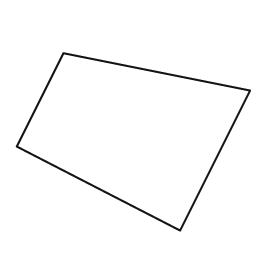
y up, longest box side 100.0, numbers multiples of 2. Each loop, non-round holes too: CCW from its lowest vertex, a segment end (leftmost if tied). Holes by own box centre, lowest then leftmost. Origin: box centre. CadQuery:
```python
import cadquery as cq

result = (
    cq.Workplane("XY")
    .moveTo(20.0, -38.0)
    .lineTo(50.0, 22.0)
    .lineTo(-30.0, 38.0)
    .lineTo(-50.0, -2.0)
    .close()
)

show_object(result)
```